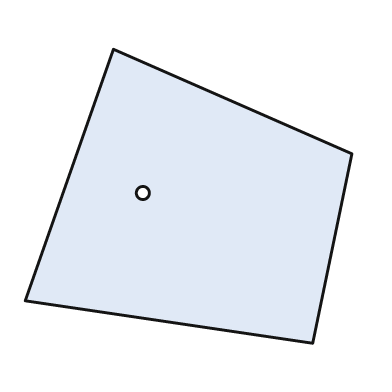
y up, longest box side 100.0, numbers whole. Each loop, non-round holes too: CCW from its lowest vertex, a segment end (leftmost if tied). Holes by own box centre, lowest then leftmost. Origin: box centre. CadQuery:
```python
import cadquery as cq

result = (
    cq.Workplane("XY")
    .moveTo(38.0, -45.0)
    .lineTo(50.0, 13.0)
    .lineTo(-23.0, 45.0)
    .lineTo(-50.0, -32.0)
    .close()
    .moveTo(-14.0, 1.0)
    .circle(2.0)
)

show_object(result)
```